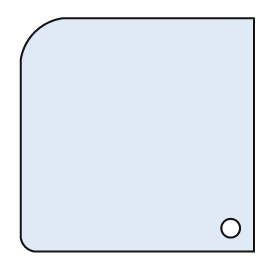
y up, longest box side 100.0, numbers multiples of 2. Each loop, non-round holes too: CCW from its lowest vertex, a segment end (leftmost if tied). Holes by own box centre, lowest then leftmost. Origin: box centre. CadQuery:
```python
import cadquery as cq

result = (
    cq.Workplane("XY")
    .moveTo(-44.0, -50.0)
    .lineTo(50.0, -50.0)
    .lineTo(50.0, 50.0)
    .lineTo(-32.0, 50.0)
    .threePointArc((-44.0, 44.0), (-50.0, 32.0))
    .lineTo(-50.0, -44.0)
    .threePointArc((-48.0, -48.0), (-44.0, -50.0))
    .close()
    .moveTo(40.0, -40.0)
    .circle(4.0)
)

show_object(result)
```